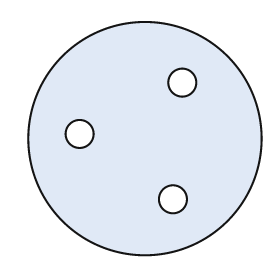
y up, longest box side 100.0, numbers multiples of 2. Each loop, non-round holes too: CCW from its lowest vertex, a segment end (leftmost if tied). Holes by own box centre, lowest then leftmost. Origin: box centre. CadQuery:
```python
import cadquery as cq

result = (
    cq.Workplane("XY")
    .moveTo(0.0, 0.0)
    .circle(50.0)
    .moveTo(12.0, -26.0)
    .circle(6.0)
    .moveTo(-28.0, 2.0)
    .circle(6.0)
    .moveTo(16.0, 24.0)
    .circle(6.0)
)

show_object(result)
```